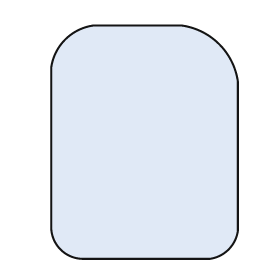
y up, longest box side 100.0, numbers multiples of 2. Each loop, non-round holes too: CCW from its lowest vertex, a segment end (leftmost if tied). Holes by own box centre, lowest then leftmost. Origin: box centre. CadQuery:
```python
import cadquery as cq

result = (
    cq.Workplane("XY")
    .moveTo(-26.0, -50.0)
    .lineTo(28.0, -50.0)
    .threePointArc((36.0, -46.0), (40.0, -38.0))
    .lineTo(40.0, 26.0)
    .threePointArc((32.0, 42.0), (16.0, 50.0))
    .lineTo(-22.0, 50.0)
    .threePointArc((-34.0, 44.0), (-40.0, 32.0))
    .lineTo(-40.0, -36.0)
    .threePointArc((-36.0, -46.0), (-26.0, -50.0))
    .close()
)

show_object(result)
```